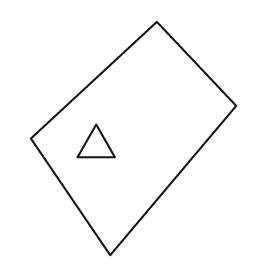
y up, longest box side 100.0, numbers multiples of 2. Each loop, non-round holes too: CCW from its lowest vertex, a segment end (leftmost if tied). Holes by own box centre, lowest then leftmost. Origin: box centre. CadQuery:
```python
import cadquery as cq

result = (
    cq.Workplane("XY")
    .moveTo(-10.0, -50.0)
    .lineTo(44.0, 14.0)
    .lineTo(10.0, 50.0)
    .lineTo(-44.0, 0.0)
    .close()
    .moveTo(-24.0, -8.0)
    .lineTo(-8.0, -8.0)
    .lineTo(-16.0, 6.0)
    .close()
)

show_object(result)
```